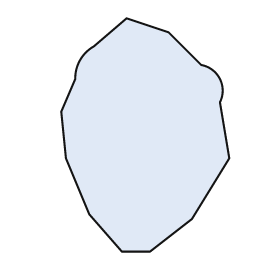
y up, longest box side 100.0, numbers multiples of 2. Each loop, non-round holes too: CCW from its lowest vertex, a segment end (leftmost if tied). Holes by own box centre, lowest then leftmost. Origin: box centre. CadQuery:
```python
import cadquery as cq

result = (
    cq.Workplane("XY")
    .moveTo(-10.0, -50.0)
    .lineTo(2.0, -50.0)
    .lineTo(20.0, -36.0)
    .lineTo(36.0, -10.0)
    .lineTo(32.0, 14.0)
    .threePointArc((32.0, 24.0), (24.0, 30.0))
    .lineTo(10.0, 44.0)
    .lineTo(-8.0, 50.0)
    .lineTo(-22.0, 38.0)
    .threePointArc((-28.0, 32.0), (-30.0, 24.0))
    .lineTo(-36.0, 10.0)
    .lineTo(-34.0, -10.0)
    .lineTo(-24.0, -34.0)
    .close()
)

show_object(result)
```